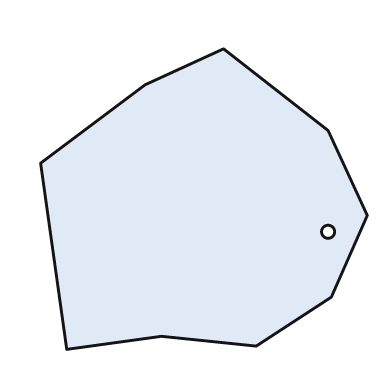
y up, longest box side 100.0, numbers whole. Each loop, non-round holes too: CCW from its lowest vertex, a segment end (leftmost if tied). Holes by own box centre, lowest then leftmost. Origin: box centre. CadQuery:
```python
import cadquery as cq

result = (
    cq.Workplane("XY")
    .moveTo(-42.0, -46.0)
    .lineTo(-13.0, -42.0)
    .lineTo(16.0, -45.0)
    .lineTo(39.0, -30.0)
    .lineTo(50.0, -5.0)
    .lineTo(38.0, 21.0)
    .lineTo(6.0, 46.0)
    .lineTo(-18.0, 35.0)
    .lineTo(-50.0, 11.0)
    .close()
    .moveTo(38.0, -10.0)
    .circle(2.0)
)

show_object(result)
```